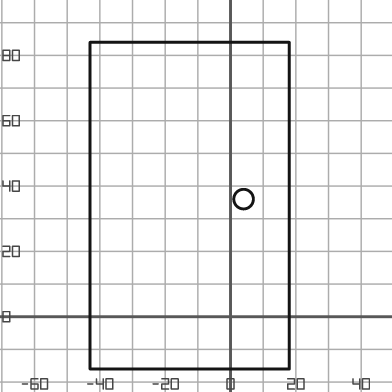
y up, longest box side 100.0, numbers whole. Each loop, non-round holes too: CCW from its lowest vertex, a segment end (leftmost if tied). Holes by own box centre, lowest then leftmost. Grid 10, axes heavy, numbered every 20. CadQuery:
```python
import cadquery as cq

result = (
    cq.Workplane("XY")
    .moveTo(-43.0, -16.0)
    .lineTo(18.0, -16.0)
    .lineTo(18.0, 84.0)
    .lineTo(-43.0, 84.0)
    .close()
    .moveTo(4.0, 36.0)
    .circle(3.0)
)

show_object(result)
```